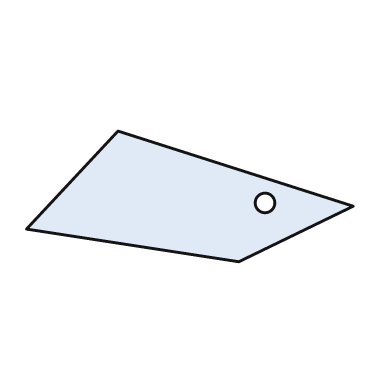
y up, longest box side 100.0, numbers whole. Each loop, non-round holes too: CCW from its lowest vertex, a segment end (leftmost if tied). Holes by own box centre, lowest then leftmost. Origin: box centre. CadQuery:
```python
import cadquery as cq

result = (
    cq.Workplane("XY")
    .moveTo(15.0, -20.0)
    .lineTo(50.0, -3.0)
    .lineTo(-22.0, 20.0)
    .lineTo(-50.0, -10.0)
    .close()
    .moveTo(23.0, -2.0)
    .circle(3.0)
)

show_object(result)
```